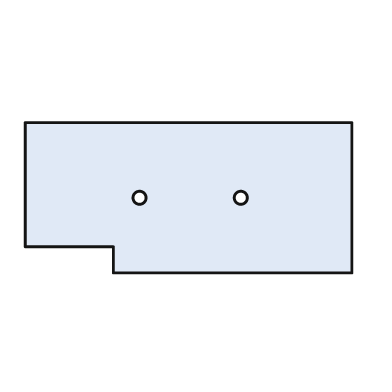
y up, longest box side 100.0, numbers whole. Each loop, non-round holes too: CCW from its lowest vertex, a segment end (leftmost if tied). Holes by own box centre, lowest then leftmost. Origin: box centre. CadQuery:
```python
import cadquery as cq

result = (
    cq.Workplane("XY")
    .moveTo(-23.0, -23.0)
    .lineTo(50.0, -23.0)
    .lineTo(50.0, 23.0)
    .lineTo(-50.0, 23.0)
    .lineTo(-50.0, -15.0)
    .lineTo(-23.0, -15.0)
    .close()
    .moveTo(-15.0, 0.0)
    .circle(2.0)
    .moveTo(16.0, 0.0)
    .circle(2.0)
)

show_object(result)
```